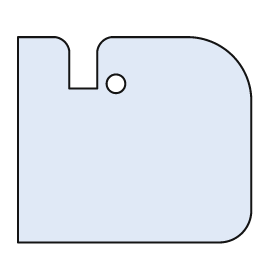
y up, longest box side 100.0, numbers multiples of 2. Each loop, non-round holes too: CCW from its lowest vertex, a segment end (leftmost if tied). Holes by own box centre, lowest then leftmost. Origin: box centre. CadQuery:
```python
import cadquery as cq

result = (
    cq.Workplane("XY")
    .moveTo(-50.0, -44.0)
    .lineTo(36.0, -44.0)
    .threePointArc((46.0, -40.0), (50.0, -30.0))
    .lineTo(50.0, 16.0)
    .threePointArc((42.0, 36.0), (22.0, 44.0))
    .lineTo(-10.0, 44.0)
    .threePointArc((-14.0, 42.0), (-16.0, 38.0))
    .lineTo(-16.0, 22.0)
    .lineTo(-28.0, 22.0)
    .lineTo(-28.0, 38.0)
    .threePointArc((-30.0, 42.0), (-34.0, 44.0))
    .lineTo(-50.0, 44.0)
    .close()
    .moveTo(-8.0, 24.0)
    .circle(4.0)
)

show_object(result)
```